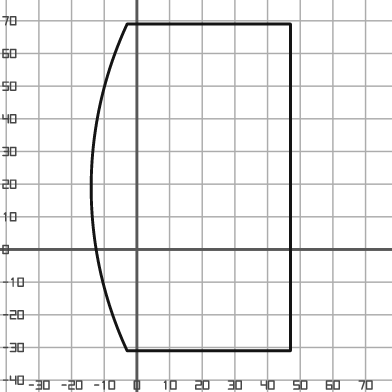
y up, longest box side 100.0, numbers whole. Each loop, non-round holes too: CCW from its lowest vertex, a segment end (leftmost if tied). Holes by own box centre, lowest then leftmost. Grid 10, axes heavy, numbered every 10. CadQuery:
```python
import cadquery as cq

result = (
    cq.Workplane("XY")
    .moveTo(-3.0, -31.0)
    .lineTo(47.0, -31.0)
    .lineTo(47.0, 69.0)
    .lineTo(-3.0, 69.0)
    .threePointArc((-14.0, 19.0), (-3.0, -31.0))
    .close()
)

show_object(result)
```